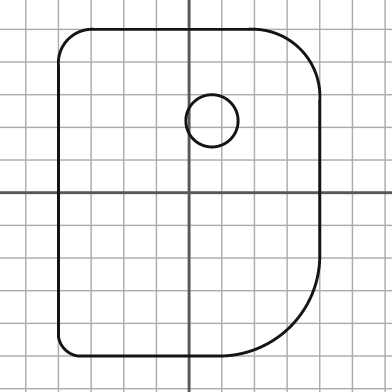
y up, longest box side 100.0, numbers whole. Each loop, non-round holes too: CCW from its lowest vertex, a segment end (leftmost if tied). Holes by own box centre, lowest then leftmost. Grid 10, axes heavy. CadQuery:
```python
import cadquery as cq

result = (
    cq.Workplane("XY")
    .moveTo(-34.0, -50.0)
    .lineTo(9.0, -50.0)
    .threePointArc((31.0, -41.0), (40.0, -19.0))
    .lineTo(40.0, 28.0)
    .threePointArc((34.0, 44.0), (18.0, 50.0))
    .lineTo(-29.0, 50.0)
    .threePointArc((-37.0, 47.0), (-40.0, 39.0))
    .lineTo(-40.0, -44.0)
    .threePointArc((-38.0, -48.0), (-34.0, -50.0))
    .close()
    .moveTo(7.0, 22.0)
    .circle(8.0)
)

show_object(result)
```